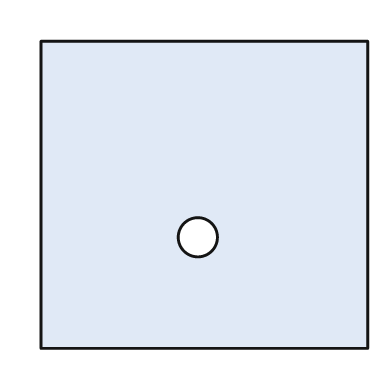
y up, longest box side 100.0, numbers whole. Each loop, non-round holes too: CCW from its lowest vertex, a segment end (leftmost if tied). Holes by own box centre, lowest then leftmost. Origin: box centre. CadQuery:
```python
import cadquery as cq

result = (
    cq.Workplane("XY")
    .moveTo(-50.0, -47.0)
    .lineTo(50.0, -47.0)
    .lineTo(50.0, 47.0)
    .lineTo(-50.0, 47.0)
    .close()
    .moveTo(-2.0, -13.0)
    .circle(6.0)
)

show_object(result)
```